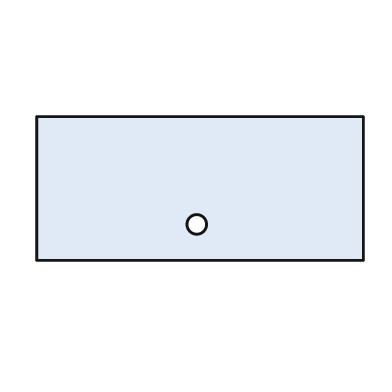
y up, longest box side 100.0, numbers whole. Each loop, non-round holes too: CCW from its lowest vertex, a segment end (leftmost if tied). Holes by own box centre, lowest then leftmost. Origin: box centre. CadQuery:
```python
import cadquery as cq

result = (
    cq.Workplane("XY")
    .moveTo(-50.0, -22.0)
    .lineTo(50.0, -22.0)
    .lineTo(50.0, 22.0)
    .lineTo(-50.0, 22.0)
    .close()
    .moveTo(-1.0, -11.0)
    .circle(3.0)
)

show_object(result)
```